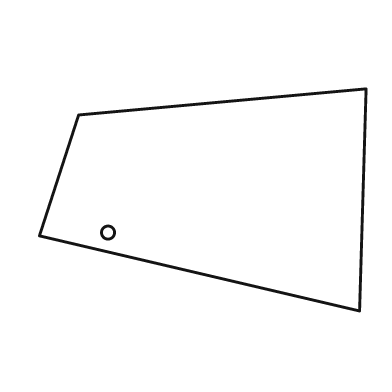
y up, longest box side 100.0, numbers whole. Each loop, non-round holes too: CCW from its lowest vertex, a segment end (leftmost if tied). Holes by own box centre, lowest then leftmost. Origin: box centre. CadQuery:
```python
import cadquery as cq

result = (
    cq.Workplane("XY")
    .moveTo(48.0, -34.0)
    .lineTo(50.0, 34.0)
    .lineTo(-38.0, 26.0)
    .lineTo(-50.0, -11.0)
    .close()
    .moveTo(-29.0, -10.0)
    .circle(2.0)
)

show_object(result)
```